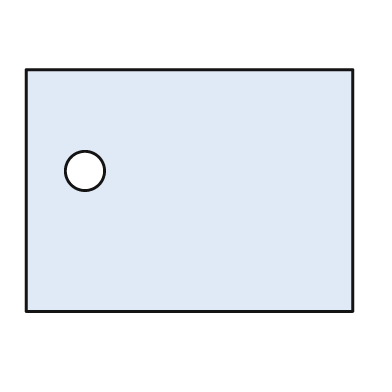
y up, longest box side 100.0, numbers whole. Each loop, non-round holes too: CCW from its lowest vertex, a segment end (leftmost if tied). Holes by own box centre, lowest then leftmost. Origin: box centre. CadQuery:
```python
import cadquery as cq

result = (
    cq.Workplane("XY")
    .moveTo(-50.0, -37.0)
    .lineTo(50.0, -37.0)
    .lineTo(50.0, 37.0)
    .lineTo(-50.0, 37.0)
    .close()
    .moveTo(-32.0, 6.0)
    .circle(6.0)
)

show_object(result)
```